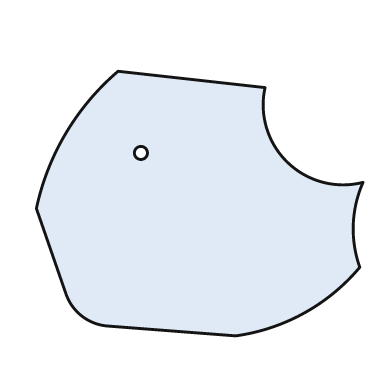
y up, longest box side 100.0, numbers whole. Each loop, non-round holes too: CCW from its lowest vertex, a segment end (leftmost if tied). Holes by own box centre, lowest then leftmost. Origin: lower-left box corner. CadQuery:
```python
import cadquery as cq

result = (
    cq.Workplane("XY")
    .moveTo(61.0, 0.0)
    .threePointArc((82.0, 7.0), (99.0, 21.0))
    .threePointArc((97.0, 34.0), (100.0, 47.0))
    .threePointArc((77.0, 53.0), (70.0, 76.0))
    .lineTo(25.0, 81.0)
    .threePointArc((9.0, 62.0), (0.0, 39.0))
    .lineTo(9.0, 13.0)
    .threePointArc((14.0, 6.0), (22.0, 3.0))
    .close()
    .moveTo(32.0, 56.0)
    .circle(2.0)
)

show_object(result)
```